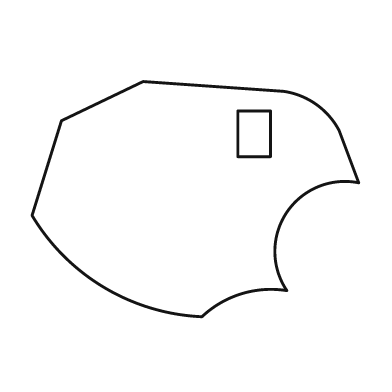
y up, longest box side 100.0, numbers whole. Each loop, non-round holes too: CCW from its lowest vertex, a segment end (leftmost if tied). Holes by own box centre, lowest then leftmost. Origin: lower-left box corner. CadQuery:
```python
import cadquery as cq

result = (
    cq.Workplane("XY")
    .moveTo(52.0, 0.0)
    .threePointArc((64.0, 7.0), (78.0, 8.0))
    .threePointArc((78.0, 32.0), (100.0, 41.0))
    .lineTo(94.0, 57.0)
    .threePointArc((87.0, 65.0), (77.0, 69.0))
    .lineTo(34.0, 72.0)
    .lineTo(9.0, 60.0)
    .lineTo(0.0, 31.0)
    .threePointArc((22.0, 9.0), (52.0, 0.0))
    .close()
    .moveTo(63.0, 49.0)
    .lineTo(73.0, 49.0)
    .lineTo(73.0, 63.0)
    .lineTo(63.0, 63.0)
    .close()
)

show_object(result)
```